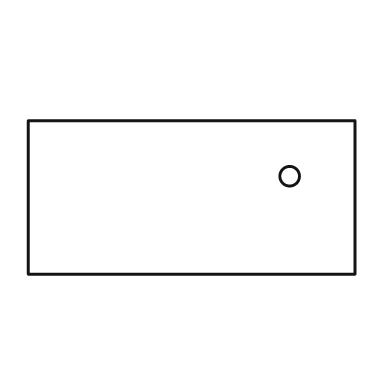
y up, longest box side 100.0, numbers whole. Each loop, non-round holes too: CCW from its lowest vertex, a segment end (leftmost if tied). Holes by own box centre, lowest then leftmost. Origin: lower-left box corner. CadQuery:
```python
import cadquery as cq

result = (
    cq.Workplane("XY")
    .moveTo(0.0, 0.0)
    .lineTo(100.0, 0.0)
    .lineTo(100.0, 47.0)
    .lineTo(0.0, 47.0)
    .close()
    .moveTo(80.0, 30.0)
    .circle(3.0)
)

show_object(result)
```